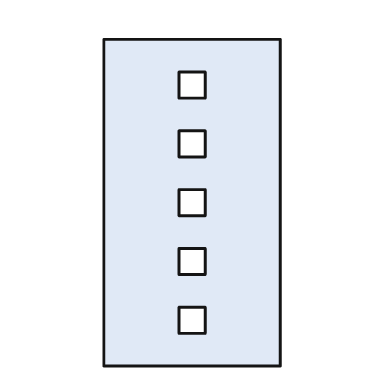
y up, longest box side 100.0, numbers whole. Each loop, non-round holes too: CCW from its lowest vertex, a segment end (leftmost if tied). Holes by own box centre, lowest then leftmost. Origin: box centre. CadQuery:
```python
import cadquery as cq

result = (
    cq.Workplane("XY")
    .moveTo(-27.0, -50.0)
    .lineTo(27.0, -50.0)
    .lineTo(27.0, 50.0)
    .lineTo(-27.0, 50.0)
    .close()
    .moveTo(-4.0, -40.0)
    .lineTo(4.0, -40.0)
    .lineTo(4.0, -32.0)
    .lineTo(-4.0, -32.0)
    .close()
    .moveTo(-4.0, -22.0)
    .lineTo(4.0, -22.0)
    .lineTo(4.0, -14.0)
    .lineTo(-4.0, -14.0)
    .close()
    .moveTo(-4.0, -4.0)
    .lineTo(4.0, -4.0)
    .lineTo(4.0, 4.0)
    .lineTo(-4.0, 4.0)
    .close()
    .moveTo(-4.0, 14.0)
    .lineTo(4.0, 14.0)
    .lineTo(4.0, 22.0)
    .lineTo(-4.0, 22.0)
    .close()
    .moveTo(-4.0, 32.0)
    .lineTo(4.0, 32.0)
    .lineTo(4.0, 40.0)
    .lineTo(-4.0, 40.0)
    .close()
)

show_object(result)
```